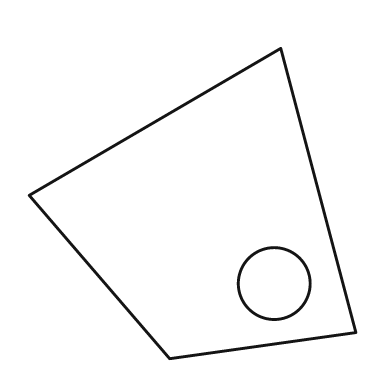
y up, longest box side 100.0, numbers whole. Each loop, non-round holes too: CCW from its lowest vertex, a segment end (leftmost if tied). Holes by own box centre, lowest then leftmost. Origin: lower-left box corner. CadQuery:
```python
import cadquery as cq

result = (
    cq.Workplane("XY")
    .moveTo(43.0, 0.0)
    .lineTo(100.0, 8.0)
    .lineTo(77.0, 95.0)
    .lineTo(0.0, 50.0)
    .close()
    .moveTo(75.0, 23.0)
    .circle(11.0)
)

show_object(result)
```